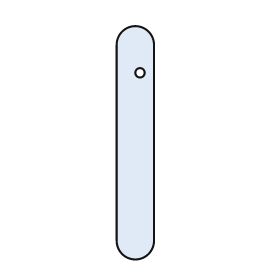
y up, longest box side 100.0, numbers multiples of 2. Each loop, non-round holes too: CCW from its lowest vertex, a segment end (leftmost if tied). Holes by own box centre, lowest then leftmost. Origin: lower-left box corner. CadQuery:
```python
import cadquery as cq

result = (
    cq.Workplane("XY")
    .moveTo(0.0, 8.0)
    .threePointArc((8.0, 0.0), (16.0, 8.0))
    .lineTo(16.0, 92.0)
    .threePointArc((8.0, 100.0), (0.0, 92.0))
    .close()
    .moveTo(10.0, 80.0)
    .circle(2.0)
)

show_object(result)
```